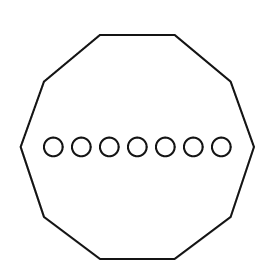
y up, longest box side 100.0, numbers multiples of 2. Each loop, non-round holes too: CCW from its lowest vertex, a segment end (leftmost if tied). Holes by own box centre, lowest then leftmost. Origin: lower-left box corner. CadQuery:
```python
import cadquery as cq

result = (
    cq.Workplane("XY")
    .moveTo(34.0, 0.0)
    .lineTo(66.0, 0.0)
    .lineTo(90.0, 18.0)
    .lineTo(100.0, 48.0)
    .lineTo(90.0, 76.0)
    .lineTo(66.0, 96.0)
    .lineTo(34.0, 96.0)
    .lineTo(10.0, 76.0)
    .lineTo(0.0, 48.0)
    .lineTo(10.0, 18.0)
    .close()
    .moveTo(14.0, 48.0)
    .circle(4.0)
    .moveTo(26.0, 48.0)
    .circle(4.0)
    .moveTo(38.0, 48.0)
    .circle(4.0)
    .moveTo(50.0, 48.0)
    .circle(4.0)
    .moveTo(62.0, 48.0)
    .circle(4.0)
    .moveTo(74.0, 48.0)
    .circle(4.0)
    .moveTo(86.0, 48.0)
    .circle(4.0)
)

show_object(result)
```